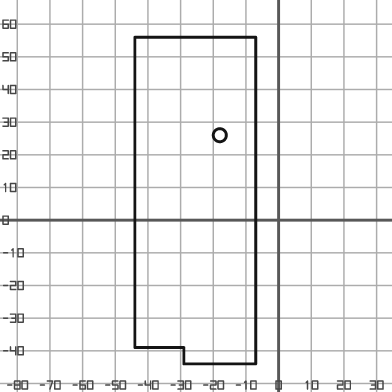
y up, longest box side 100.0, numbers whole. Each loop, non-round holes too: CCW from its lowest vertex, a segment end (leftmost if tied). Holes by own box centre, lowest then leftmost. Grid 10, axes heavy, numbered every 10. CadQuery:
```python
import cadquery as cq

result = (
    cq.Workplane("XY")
    .moveTo(-29.0, -44.0)
    .lineTo(-7.0, -44.0)
    .lineTo(-7.0, 56.0)
    .lineTo(-44.0, 56.0)
    .lineTo(-44.0, -39.0)
    .lineTo(-29.0, -39.0)
    .close()
    .moveTo(-18.0, 26.0)
    .circle(2.0)
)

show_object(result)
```